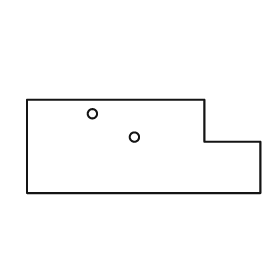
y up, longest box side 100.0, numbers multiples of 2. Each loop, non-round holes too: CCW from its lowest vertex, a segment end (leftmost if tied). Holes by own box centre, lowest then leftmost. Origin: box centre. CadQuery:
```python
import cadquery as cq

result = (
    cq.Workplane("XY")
    .moveTo(-50.0, -20.0)
    .lineTo(50.0, -20.0)
    .lineTo(50.0, 2.0)
    .lineTo(26.0, 2.0)
    .lineTo(26.0, 20.0)
    .lineTo(-50.0, 20.0)
    .close()
    .moveTo(-4.0, 4.0)
    .circle(2.0)
    .moveTo(-22.0, 14.0)
    .circle(2.0)
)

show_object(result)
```